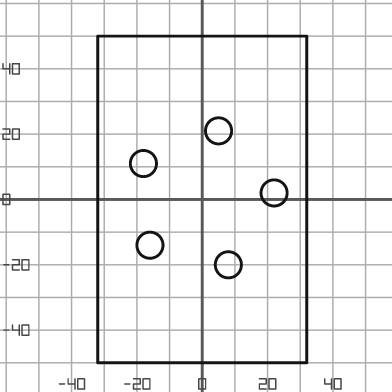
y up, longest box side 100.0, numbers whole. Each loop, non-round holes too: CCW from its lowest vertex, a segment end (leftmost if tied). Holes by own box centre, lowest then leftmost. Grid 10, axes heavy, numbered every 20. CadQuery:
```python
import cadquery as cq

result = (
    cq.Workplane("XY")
    .moveTo(-32.0, -50.0)
    .lineTo(32.0, -50.0)
    .lineTo(32.0, 50.0)
    .lineTo(-32.0, 50.0)
    .close()
    .moveTo(8.0, -20.0)
    .circle(4.0)
    .moveTo(-16.0, -14.0)
    .circle(4.0)
    .moveTo(22.0, 2.0)
    .circle(4.0)
    .moveTo(-18.0, 11.0)
    .circle(4.0)
    .moveTo(5.0, 21.0)
    .circle(4.0)
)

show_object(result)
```